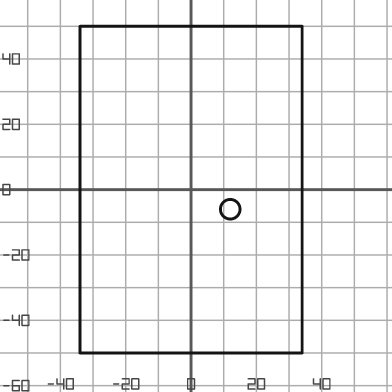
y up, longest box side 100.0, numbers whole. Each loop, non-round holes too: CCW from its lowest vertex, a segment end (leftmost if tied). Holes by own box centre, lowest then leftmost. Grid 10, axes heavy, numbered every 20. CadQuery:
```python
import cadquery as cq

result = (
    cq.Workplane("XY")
    .moveTo(-34.0, -50.0)
    .lineTo(34.0, -50.0)
    .lineTo(34.0, 50.0)
    .lineTo(-34.0, 50.0)
    .close()
    .moveTo(12.0, -6.0)
    .circle(3.0)
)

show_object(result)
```